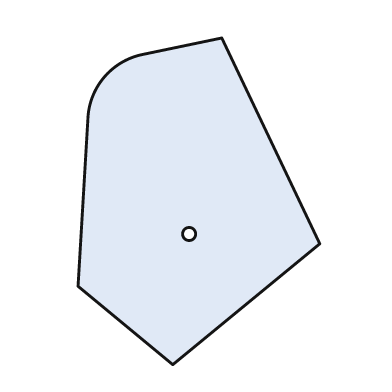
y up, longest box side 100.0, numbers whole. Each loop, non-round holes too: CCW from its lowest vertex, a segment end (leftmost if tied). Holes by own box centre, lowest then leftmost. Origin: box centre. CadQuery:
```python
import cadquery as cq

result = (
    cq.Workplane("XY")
    .moveTo(-8.0, -50.0)
    .lineTo(37.0, -13.0)
    .lineTo(7.0, 50.0)
    .lineTo(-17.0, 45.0)
    .threePointArc((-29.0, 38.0), (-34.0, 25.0))
    .lineTo(-37.0, -26.0)
    .close()
    .moveTo(-3.0, -10.0)
    .circle(2.0)
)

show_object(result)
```